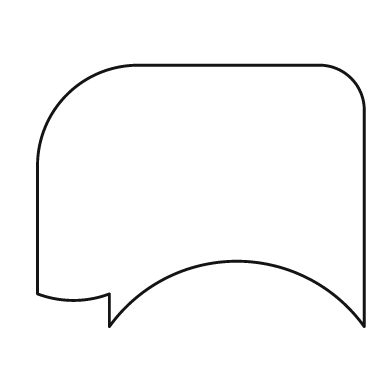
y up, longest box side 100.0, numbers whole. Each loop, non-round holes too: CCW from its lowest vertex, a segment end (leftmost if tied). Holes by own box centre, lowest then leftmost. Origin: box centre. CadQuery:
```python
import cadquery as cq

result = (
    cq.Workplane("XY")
    .moveTo(-28.0, -40.0)
    .threePointArc((11.0, -20.0), (50.0, -40.0))
    .lineTo(50.0, 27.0)
    .threePointArc((46.0, 36.0), (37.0, 40.0))
    .lineTo(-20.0, 40.0)
    .threePointArc((-41.0, 31.0), (-50.0, 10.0))
    .lineTo(-50.0, -30.0)
    .threePointArc((-39.0, -32.0), (-28.0, -30.0))
    .close()
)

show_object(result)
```